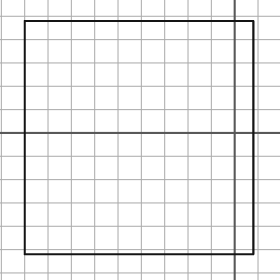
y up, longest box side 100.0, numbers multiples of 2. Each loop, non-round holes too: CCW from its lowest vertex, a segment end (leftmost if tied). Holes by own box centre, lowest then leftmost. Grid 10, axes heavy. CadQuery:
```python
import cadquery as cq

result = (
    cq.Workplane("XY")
    .moveTo(-90.0, -52.0)
    .lineTo(8.0, -52.0)
    .lineTo(8.0, 48.0)
    .lineTo(-90.0, 48.0)
    .close()
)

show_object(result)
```